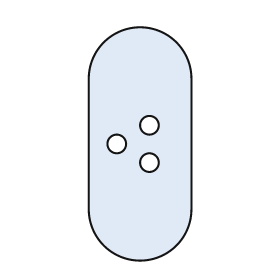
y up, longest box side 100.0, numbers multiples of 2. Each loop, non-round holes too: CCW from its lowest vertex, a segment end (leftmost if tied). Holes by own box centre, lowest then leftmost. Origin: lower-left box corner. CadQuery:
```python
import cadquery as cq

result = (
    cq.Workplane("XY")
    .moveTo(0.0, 22.0)
    .threePointArc((22.0, 0.0), (44.0, 22.0))
    .lineTo(44.0, 78.0)
    .threePointArc((22.0, 100.0), (0.0, 78.0))
    .close()
    .moveTo(26.0, 42.0)
    .circle(4.0)
    .moveTo(12.0, 50.0)
    .circle(4.0)
    .moveTo(26.0, 58.0)
    .circle(4.0)
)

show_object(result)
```